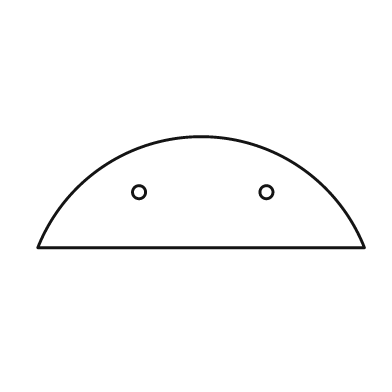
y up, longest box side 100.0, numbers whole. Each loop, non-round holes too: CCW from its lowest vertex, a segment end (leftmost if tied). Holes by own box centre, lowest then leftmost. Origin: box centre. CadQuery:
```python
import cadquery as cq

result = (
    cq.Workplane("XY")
    .moveTo(-50.0, -17.0)
    .lineTo(50.0, -17.0)
    .threePointArc((0.0, 17.0), (-50.0, -17.0))
    .close()
    .moveTo(-19.0, 0.0)
    .circle(2.0)
    .moveTo(20.0, 0.0)
    .circle(2.0)
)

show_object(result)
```